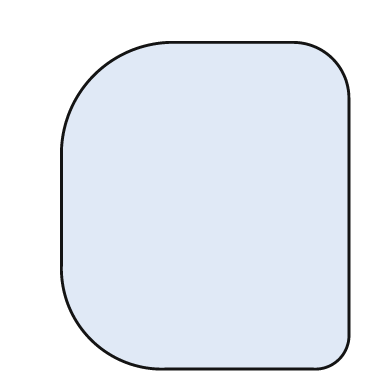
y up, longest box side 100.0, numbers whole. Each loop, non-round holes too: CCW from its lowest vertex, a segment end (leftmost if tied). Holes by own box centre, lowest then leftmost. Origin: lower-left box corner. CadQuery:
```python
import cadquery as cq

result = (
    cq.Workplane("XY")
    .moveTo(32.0, 0.0)
    .lineTo(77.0, 0.0)
    .threePointArc((85.0, 3.0), (88.0, 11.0))
    .lineTo(88.0, 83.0)
    .threePointArc((83.0, 95.0), (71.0, 100.0))
    .lineTo(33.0, 100.0)
    .threePointArc((10.0, 90.0), (0.0, 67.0))
    .lineTo(0.0, 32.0)
    .threePointArc((9.0, 9.0), (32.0, 0.0))
    .close()
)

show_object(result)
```